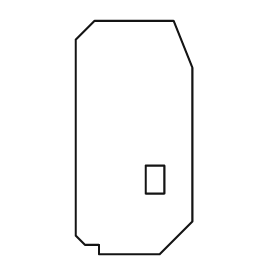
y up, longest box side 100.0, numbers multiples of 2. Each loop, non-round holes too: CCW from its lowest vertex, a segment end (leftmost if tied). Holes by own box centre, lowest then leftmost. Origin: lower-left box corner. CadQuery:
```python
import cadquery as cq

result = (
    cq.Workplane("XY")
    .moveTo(10.0, 0.0)
    .lineTo(36.0, 0.0)
    .lineTo(50.0, 14.0)
    .lineTo(50.0, 80.0)
    .lineTo(42.0, 100.0)
    .lineTo(8.0, 100.0)
    .lineTo(0.0, 92.0)
    .lineTo(0.0, 8.0)
    .lineTo(4.0, 4.0)
    .lineTo(10.0, 4.0)
    .close()
    .moveTo(30.0, 26.0)
    .lineTo(38.0, 26.0)
    .lineTo(38.0, 38.0)
    .lineTo(30.0, 38.0)
    .close()
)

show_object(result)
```